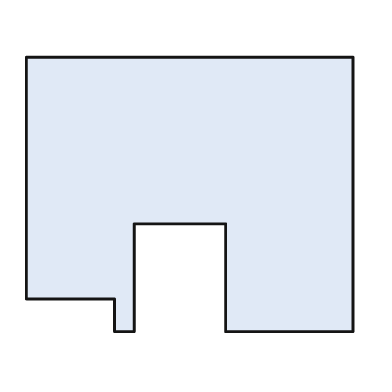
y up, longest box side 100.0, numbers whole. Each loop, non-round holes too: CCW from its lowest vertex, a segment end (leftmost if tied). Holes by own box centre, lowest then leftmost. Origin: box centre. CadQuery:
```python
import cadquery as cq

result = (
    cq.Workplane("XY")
    .moveTo(-23.0, -42.0)
    .lineTo(-17.0, -42.0)
    .lineTo(-17.0, -9.0)
    .lineTo(11.0, -9.0)
    .lineTo(11.0, -42.0)
    .lineTo(50.0, -42.0)
    .lineTo(50.0, 42.0)
    .lineTo(-50.0, 42.0)
    .lineTo(-50.0, -32.0)
    .lineTo(-23.0, -32.0)
    .close()
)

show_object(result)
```